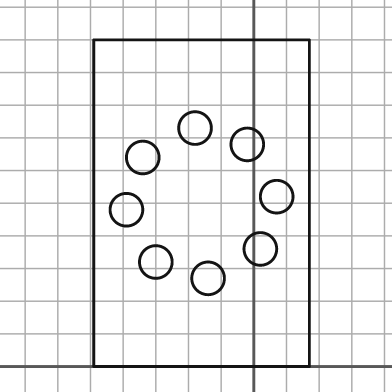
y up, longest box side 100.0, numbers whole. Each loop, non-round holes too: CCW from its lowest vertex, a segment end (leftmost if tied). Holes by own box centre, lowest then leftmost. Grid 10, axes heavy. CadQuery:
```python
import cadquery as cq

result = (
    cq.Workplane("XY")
    .moveTo(-49.0, 0.0)
    .lineTo(17.0, 0.0)
    .lineTo(17.0, 100.0)
    .lineTo(-49.0, 100.0)
    .close()
    .moveTo(-14.0, 27.0)
    .circle(5.0)
    .moveTo(-30.0, 32.0)
    .circle(5.0)
    .moveTo(2.0, 36.0)
    .circle(5.0)
    .moveTo(-39.0, 48.0)
    .circle(5.0)
    .moveTo(7.0, 52.0)
    .circle(5.0)
    .moveTo(-34.0, 64.0)
    .circle(5.0)
    .moveTo(-2.0, 68.0)
    .circle(5.0)
    .moveTo(-18.0, 73.0)
    .circle(5.0)
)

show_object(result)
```